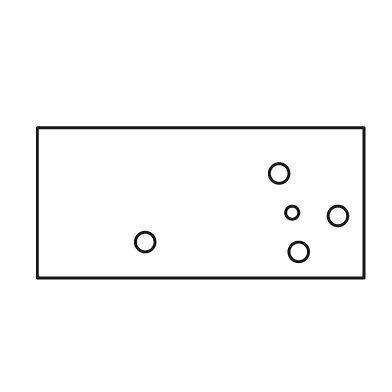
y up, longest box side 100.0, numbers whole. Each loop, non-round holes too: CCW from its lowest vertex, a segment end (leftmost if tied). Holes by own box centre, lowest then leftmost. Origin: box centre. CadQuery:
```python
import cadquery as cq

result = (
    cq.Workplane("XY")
    .moveTo(-50.0, -23.0)
    .lineTo(50.0, -23.0)
    .lineTo(50.0, 23.0)
    .lineTo(-50.0, 23.0)
    .close()
    .moveTo(30.0, -15.0)
    .circle(3.0)
    .moveTo(-17.0, -12.0)
    .circle(3.0)
    .moveTo(42.0, -4.0)
    .circle(3.0)
    .moveTo(28.0, -3.0)
    .circle(2.0)
    .moveTo(24.0, 9.0)
    .circle(3.0)
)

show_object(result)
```